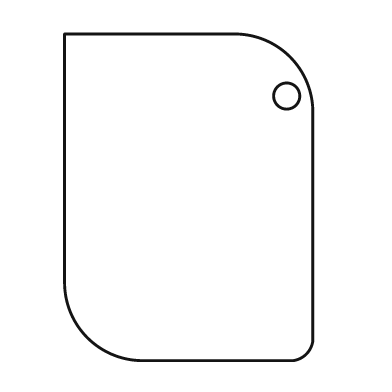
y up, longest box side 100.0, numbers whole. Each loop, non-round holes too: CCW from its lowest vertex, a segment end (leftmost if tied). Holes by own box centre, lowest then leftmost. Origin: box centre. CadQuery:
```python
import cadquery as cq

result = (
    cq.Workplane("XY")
    .moveTo(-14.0, -50.0)
    .lineTo(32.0, -50.0)
    .threePointArc((36.0, -48.0), (38.0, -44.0))
    .lineTo(38.0, 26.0)
    .threePointArc((31.0, 43.0), (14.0, 50.0))
    .lineTo(-38.0, 50.0)
    .lineTo(-38.0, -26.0)
    .threePointArc((-31.0, -43.0), (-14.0, -50.0))
    .close()
    .moveTo(30.0, 31.0)
    .circle(4.0)
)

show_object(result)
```